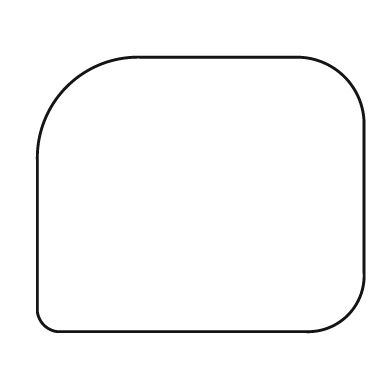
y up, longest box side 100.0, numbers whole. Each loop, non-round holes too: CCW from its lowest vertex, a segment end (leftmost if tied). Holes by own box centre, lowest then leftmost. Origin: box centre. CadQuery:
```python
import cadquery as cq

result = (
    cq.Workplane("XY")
    .moveTo(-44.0, -42.0)
    .lineTo(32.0, -42.0)
    .threePointArc((45.0, -37.0), (50.0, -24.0))
    .lineTo(50.0, 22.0)
    .threePointArc((44.0, 36.0), (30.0, 42.0))
    .lineTo(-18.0, 42.0)
    .threePointArc((-41.0, 33.0), (-50.0, 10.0))
    .lineTo(-50.0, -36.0)
    .threePointArc((-48.0, -40.0), (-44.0, -42.0))
    .close()
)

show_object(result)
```